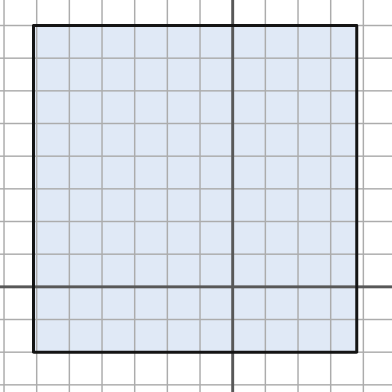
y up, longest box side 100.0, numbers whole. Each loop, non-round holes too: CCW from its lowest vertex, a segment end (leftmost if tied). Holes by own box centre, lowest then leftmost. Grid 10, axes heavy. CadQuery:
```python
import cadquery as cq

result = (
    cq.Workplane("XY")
    .moveTo(-61.0, -20.0)
    .lineTo(38.0, -20.0)
    .lineTo(38.0, 80.0)
    .lineTo(-61.0, 80.0)
    .close()
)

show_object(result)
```